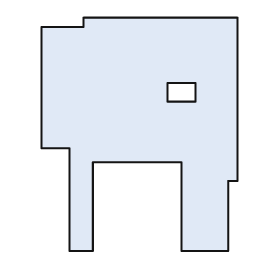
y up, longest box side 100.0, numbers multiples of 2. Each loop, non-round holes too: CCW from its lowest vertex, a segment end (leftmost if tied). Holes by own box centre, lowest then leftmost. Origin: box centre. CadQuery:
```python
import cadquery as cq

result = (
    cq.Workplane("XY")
    .moveTo(-30.0, -50.0)
    .lineTo(-20.0, -50.0)
    .lineTo(-20.0, -12.0)
    .lineTo(18.0, -12.0)
    .lineTo(18.0, -50.0)
    .lineTo(38.0, -50.0)
    .lineTo(38.0, -20.0)
    .lineTo(42.0, -20.0)
    .lineTo(42.0, 50.0)
    .lineTo(-24.0, 50.0)
    .lineTo(-24.0, 46.0)
    .lineTo(-42.0, 46.0)
    .lineTo(-42.0, -6.0)
    .lineTo(-30.0, -6.0)
    .close()
    .moveTo(12.0, 14.0)
    .lineTo(24.0, 14.0)
    .lineTo(24.0, 22.0)
    .lineTo(12.0, 22.0)
    .close()
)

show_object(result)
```